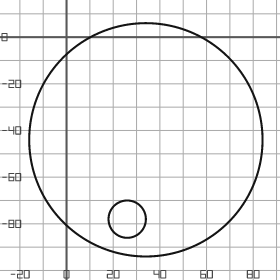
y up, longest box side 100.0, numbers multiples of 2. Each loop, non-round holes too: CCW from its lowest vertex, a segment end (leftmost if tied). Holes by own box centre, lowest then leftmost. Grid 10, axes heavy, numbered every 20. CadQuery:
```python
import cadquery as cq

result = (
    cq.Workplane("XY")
    .moveTo(34.0, -44.0)
    .circle(50.0)
    .moveTo(26.0, -78.0)
    .circle(8.0)
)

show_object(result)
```